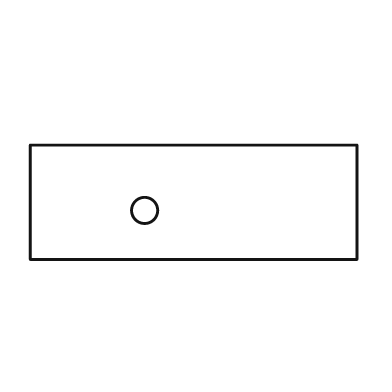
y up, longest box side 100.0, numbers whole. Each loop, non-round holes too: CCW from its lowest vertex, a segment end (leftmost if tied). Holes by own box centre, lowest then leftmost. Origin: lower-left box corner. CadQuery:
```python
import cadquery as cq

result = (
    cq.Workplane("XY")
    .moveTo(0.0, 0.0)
    .lineTo(100.0, 0.0)
    .lineTo(100.0, 35.0)
    .lineTo(0.0, 35.0)
    .close()
    .moveTo(35.0, 15.0)
    .circle(4.0)
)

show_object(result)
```